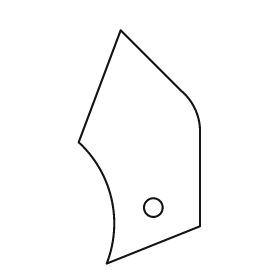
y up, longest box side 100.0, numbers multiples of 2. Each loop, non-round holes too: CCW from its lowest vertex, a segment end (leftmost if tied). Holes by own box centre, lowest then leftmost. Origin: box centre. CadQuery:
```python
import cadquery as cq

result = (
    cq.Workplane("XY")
    .moveTo(-14.0, -50.0)
    .lineTo(26.0, -34.0)
    .lineTo(26.0, 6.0)
    .threePointArc((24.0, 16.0), (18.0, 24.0))
    .lineTo(-8.0, 50.0)
    .lineTo(-26.0, 2.0)
    .threePointArc((-12.0, -22.0), (-14.0, -50.0))
    .close()
    .moveTo(6.0, -26.0)
    .circle(4.0)
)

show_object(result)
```